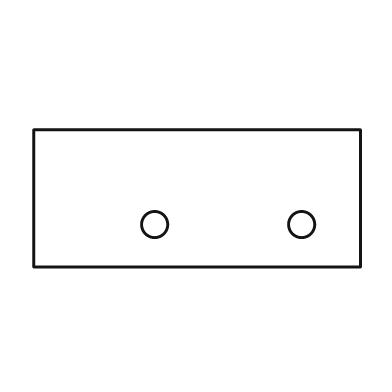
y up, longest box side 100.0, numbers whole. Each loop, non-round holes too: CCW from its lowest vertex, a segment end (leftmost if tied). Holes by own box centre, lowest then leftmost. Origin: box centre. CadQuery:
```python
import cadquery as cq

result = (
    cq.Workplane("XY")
    .moveTo(-50.0, -21.0)
    .lineTo(50.0, -21.0)
    .lineTo(50.0, 21.0)
    .lineTo(-50.0, 21.0)
    .close()
    .moveTo(-13.0, -8.0)
    .circle(4.0)
    .moveTo(32.0, -8.0)
    .circle(4.0)
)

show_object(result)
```